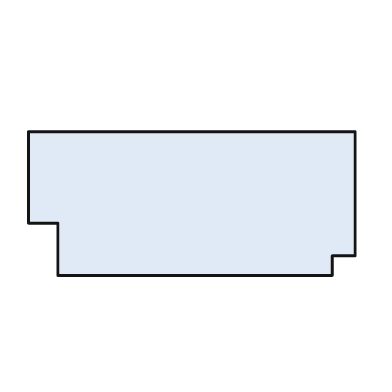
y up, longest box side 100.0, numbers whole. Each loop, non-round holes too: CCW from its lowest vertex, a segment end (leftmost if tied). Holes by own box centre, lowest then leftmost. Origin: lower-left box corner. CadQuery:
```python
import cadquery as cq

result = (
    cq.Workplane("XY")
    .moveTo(9.0, 0.0)
    .lineTo(93.0, 0.0)
    .lineTo(93.0, 6.0)
    .lineTo(100.0, 6.0)
    .lineTo(100.0, 44.0)
    .lineTo(0.0, 44.0)
    .lineTo(0.0, 16.0)
    .lineTo(9.0, 16.0)
    .close()
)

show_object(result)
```